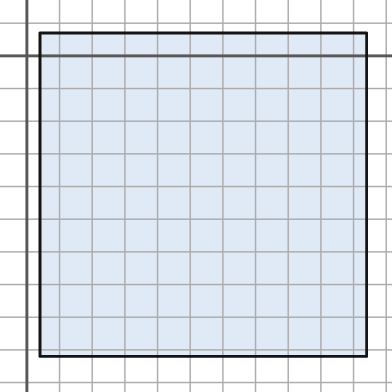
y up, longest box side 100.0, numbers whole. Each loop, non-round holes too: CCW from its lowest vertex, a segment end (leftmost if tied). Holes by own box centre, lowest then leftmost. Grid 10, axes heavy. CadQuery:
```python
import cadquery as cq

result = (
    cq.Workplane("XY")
    .moveTo(4.0, -92.0)
    .lineTo(104.0, -92.0)
    .lineTo(104.0, 7.0)
    .lineTo(4.0, 7.0)
    .close()
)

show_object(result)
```